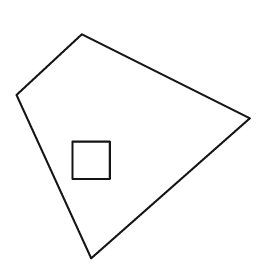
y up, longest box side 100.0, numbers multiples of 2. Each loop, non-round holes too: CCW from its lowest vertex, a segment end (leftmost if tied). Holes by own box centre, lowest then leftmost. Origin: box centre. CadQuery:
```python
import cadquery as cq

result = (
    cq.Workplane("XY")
    .moveTo(-18.0, -48.0)
    .lineTo(50.0, 12.0)
    .lineTo(-22.0, 48.0)
    .lineTo(-50.0, 22.0)
    .close()
    .moveTo(-26.0, -14.0)
    .lineTo(-10.0, -14.0)
    .lineTo(-10.0, 2.0)
    .lineTo(-26.0, 2.0)
    .close()
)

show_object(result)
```